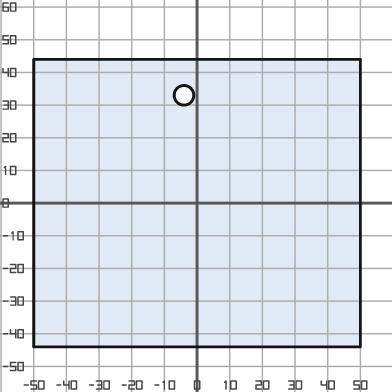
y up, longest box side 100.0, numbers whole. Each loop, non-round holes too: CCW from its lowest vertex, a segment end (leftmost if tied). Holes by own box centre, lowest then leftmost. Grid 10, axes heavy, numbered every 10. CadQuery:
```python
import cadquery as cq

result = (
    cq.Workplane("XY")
    .moveTo(-50.0, -44.0)
    .lineTo(50.0, -44.0)
    .lineTo(50.0, 44.0)
    .lineTo(-50.0, 44.0)
    .close()
    .moveTo(-4.0, 33.0)
    .circle(3.0)
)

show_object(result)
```